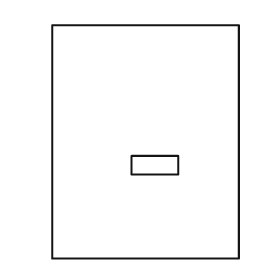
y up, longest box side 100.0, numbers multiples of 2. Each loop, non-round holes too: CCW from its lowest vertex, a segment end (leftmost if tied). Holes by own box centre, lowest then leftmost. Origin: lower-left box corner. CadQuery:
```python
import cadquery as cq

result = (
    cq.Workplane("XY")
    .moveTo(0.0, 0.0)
    .lineTo(80.0, 0.0)
    .lineTo(80.0, 100.0)
    .lineTo(0.0, 100.0)
    .close()
    .moveTo(34.0, 36.0)
    .lineTo(54.0, 36.0)
    .lineTo(54.0, 44.0)
    .lineTo(34.0, 44.0)
    .close()
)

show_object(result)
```